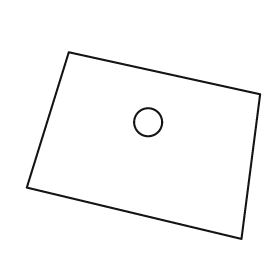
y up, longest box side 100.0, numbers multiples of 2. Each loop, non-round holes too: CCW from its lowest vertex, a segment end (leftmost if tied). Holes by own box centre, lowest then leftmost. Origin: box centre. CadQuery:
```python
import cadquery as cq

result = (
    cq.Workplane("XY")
    .moveTo(42.0, -40.0)
    .lineTo(50.0, 22.0)
    .lineTo(-32.0, 40.0)
    .lineTo(-50.0, -18.0)
    .close()
    .moveTo(2.0, 10.0)
    .circle(6.0)
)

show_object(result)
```